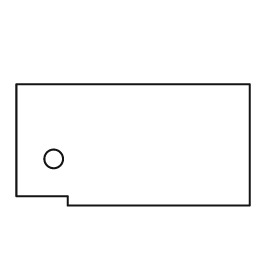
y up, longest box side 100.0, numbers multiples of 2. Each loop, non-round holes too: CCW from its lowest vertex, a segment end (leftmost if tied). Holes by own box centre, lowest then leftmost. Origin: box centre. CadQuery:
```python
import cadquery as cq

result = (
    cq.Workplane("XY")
    .moveTo(-28.0, -26.0)
    .lineTo(50.0, -26.0)
    .lineTo(50.0, 26.0)
    .lineTo(-50.0, 26.0)
    .lineTo(-50.0, -22.0)
    .lineTo(-28.0, -22.0)
    .close()
    .moveTo(-34.0, -6.0)
    .circle(4.0)
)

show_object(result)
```